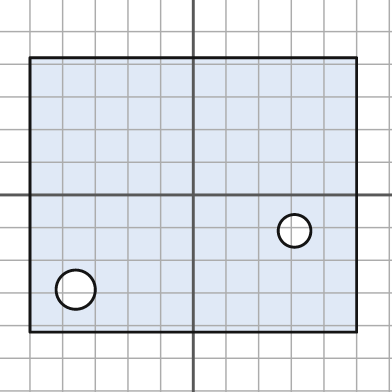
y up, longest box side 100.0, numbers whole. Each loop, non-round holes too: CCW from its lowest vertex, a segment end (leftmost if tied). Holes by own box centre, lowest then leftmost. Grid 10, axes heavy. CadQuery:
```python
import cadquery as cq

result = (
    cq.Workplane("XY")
    .moveTo(-50.0, -42.0)
    .lineTo(50.0, -42.0)
    .lineTo(50.0, 42.0)
    .lineTo(-50.0, 42.0)
    .close()
    .moveTo(-36.0, -29.0)
    .circle(6.0)
    .moveTo(31.0, -11.0)
    .circle(5.0)
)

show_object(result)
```